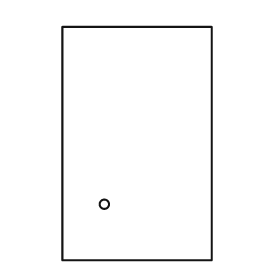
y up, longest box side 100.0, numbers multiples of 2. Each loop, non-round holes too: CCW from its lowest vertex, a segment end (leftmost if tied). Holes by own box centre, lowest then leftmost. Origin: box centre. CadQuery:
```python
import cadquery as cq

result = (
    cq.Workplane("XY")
    .moveTo(-32.0, -50.0)
    .lineTo(32.0, -50.0)
    .lineTo(32.0, 50.0)
    .lineTo(-32.0, 50.0)
    .close()
    .moveTo(-14.0, -26.0)
    .circle(2.0)
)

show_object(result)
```